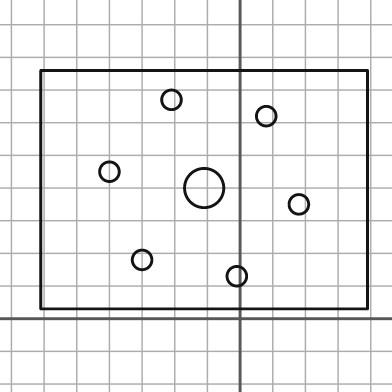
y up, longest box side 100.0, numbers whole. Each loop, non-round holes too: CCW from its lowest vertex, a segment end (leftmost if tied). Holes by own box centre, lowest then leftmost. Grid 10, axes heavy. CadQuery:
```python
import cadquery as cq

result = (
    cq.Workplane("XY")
    .moveTo(-61.0, 3.0)
    .lineTo(39.0, 3.0)
    .lineTo(39.0, 76.0)
    .lineTo(-61.0, 76.0)
    .close()
    .moveTo(-1.0, 13.0)
    .circle(3.0)
    .moveTo(-30.0, 18.0)
    .circle(3.0)
    .moveTo(18.0, 35.0)
    .circle(3.0)
    .moveTo(-11.0, 40.0)
    .circle(6.0)
    .moveTo(-40.0, 45.0)
    .circle(3.0)
    .moveTo(8.0, 62.0)
    .circle(3.0)
    .moveTo(-21.0, 67.0)
    .circle(3.0)
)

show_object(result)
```